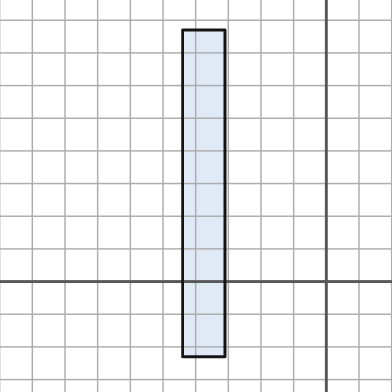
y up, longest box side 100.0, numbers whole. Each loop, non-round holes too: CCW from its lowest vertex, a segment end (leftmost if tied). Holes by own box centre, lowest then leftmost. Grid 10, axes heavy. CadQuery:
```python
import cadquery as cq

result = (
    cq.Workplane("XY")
    .moveTo(-44.0, -23.0)
    .lineTo(-31.0, -23.0)
    .lineTo(-31.0, 77.0)
    .lineTo(-44.0, 77.0)
    .close()
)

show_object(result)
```